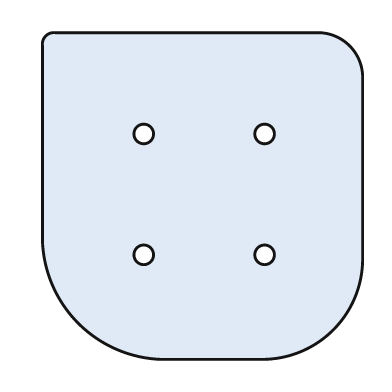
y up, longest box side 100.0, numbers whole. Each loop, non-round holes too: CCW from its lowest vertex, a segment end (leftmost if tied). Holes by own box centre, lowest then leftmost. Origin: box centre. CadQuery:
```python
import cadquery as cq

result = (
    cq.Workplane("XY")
    .moveTo(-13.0, -50.0)
    .lineTo(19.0, -50.0)
    .threePointArc((40.0, -41.0), (49.0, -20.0))
    .lineTo(49.0, 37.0)
    .threePointArc((45.0, 46.0), (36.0, 50.0))
    .lineTo(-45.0, 50.0)
    .threePointArc((-48.0, 49.0), (-49.0, 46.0))
    .lineTo(-49.0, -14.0)
    .threePointArc((-38.0, -39.0), (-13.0, -50.0))
    .close()
    .moveTo(-18.0, -18.0)
    .circle(3.0)
    .moveTo(19.0, -18.0)
    .circle(3.0)
    .moveTo(-18.0, 19.0)
    .circle(3.0)
    .moveTo(19.0, 19.0)
    .circle(3.0)
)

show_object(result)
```